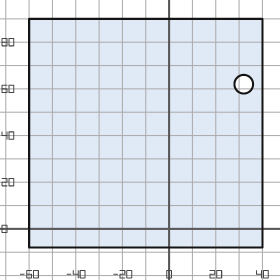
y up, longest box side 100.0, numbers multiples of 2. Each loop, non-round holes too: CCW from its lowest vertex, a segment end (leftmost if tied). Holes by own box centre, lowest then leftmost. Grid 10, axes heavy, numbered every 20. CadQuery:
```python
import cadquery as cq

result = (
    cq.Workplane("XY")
    .moveTo(-60.0, -8.0)
    .lineTo(40.0, -8.0)
    .lineTo(40.0, 90.0)
    .lineTo(-60.0, 90.0)
    .close()
    .moveTo(32.0, 62.0)
    .circle(4.0)
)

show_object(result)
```